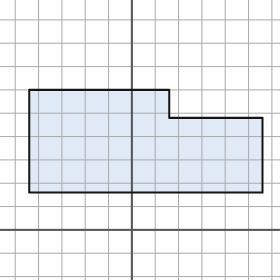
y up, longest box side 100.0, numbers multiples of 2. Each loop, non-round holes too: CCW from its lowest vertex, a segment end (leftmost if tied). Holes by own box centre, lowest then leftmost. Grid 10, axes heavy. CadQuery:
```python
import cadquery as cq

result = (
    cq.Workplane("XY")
    .moveTo(-44.0, 16.0)
    .lineTo(56.0, 16.0)
    .lineTo(56.0, 48.0)
    .lineTo(16.0, 48.0)
    .lineTo(16.0, 60.0)
    .lineTo(-44.0, 60.0)
    .close()
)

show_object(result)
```